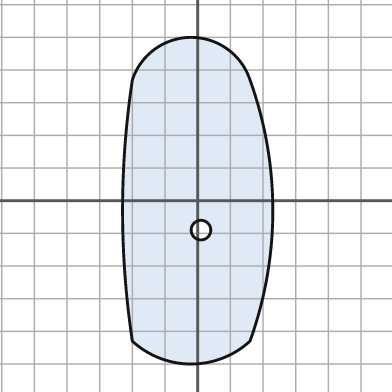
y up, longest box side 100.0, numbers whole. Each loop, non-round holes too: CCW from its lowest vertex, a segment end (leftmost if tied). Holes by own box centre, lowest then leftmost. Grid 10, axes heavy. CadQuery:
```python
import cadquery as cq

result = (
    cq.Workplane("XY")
    .moveTo(-20.0, -43.0)
    .threePointArc((-2.0, -50.0), (16.0, -43.0))
    .threePointArc((23.0, -3.0), (16.0, 37.0))
    .threePointArc((-2.0, 50.0), (-20.0, 37.0))
    .threePointArc((-23.0, -3.0), (-20.0, -43.0))
    .close()
    .moveTo(1.0, -9.0)
    .circle(3.0)
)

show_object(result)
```